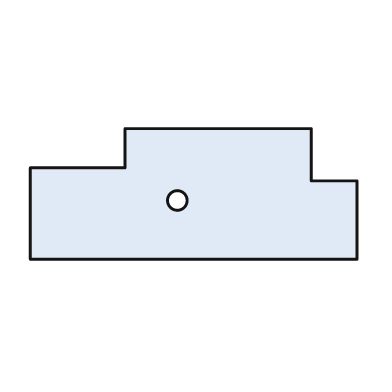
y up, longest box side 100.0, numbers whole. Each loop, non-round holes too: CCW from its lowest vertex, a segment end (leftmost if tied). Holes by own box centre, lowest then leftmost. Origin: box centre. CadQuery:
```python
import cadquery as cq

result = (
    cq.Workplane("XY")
    .moveTo(-50.0, -20.0)
    .lineTo(50.0, -20.0)
    .lineTo(50.0, 4.0)
    .lineTo(36.0, 4.0)
    .lineTo(36.0, 20.0)
    .lineTo(-21.0, 20.0)
    .lineTo(-21.0, 8.0)
    .lineTo(-50.0, 8.0)
    .close()
    .moveTo(-5.0, -2.0)
    .circle(3.0)
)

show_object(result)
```